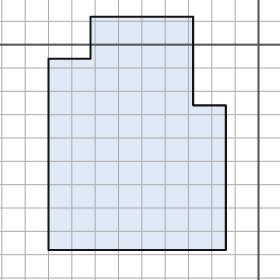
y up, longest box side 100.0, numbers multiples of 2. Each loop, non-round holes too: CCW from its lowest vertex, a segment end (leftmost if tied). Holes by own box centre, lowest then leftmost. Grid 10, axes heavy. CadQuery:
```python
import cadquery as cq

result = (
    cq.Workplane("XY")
    .moveTo(-90.0, -88.0)
    .lineTo(-14.0, -88.0)
    .lineTo(-14.0, -26.0)
    .lineTo(-28.0, -26.0)
    .lineTo(-28.0, 12.0)
    .lineTo(-72.0, 12.0)
    .lineTo(-72.0, -6.0)
    .lineTo(-90.0, -6.0)
    .close()
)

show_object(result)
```